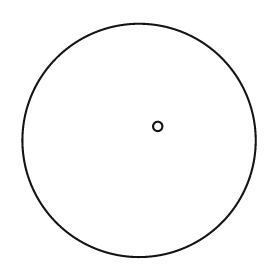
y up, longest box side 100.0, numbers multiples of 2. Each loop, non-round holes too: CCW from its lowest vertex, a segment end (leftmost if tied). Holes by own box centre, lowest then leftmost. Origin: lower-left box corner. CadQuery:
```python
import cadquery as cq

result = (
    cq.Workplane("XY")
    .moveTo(50.0, 50.0)
    .circle(50.0)
    .moveTo(58.0, 56.0)
    .circle(2.0)
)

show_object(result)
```